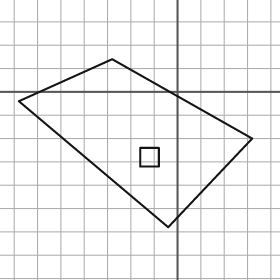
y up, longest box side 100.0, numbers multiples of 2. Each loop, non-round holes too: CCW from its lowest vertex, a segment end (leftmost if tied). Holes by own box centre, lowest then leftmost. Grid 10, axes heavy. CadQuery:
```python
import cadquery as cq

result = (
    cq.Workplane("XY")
    .moveTo(-4.0, -58.0)
    .lineTo(32.0, -20.0)
    .lineTo(-28.0, 14.0)
    .lineTo(-68.0, -4.0)
    .close()
    .moveTo(-16.0, -32.0)
    .lineTo(-8.0, -32.0)
    .lineTo(-8.0, -24.0)
    .lineTo(-16.0, -24.0)
    .close()
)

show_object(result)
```